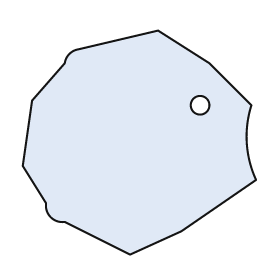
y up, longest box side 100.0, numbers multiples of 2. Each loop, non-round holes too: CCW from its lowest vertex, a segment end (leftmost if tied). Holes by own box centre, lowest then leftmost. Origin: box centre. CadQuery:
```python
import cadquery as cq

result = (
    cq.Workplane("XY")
    .moveTo(-4.0, -48.0)
    .lineTo(18.0, -38.0)
    .lineTo(50.0, -16.0)
    .threePointArc((46.0, 0.0), (48.0, 16.0))
    .lineTo(30.0, 34.0)
    .lineTo(8.0, 48.0)
    .lineTo(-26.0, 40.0)
    .threePointArc((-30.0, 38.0), (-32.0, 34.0))
    .lineTo(-46.0, 18.0)
    .lineTo(-50.0, -10.0)
    .lineTo(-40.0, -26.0)
    .threePointArc((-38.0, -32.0), (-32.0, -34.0))
    .close()
    .moveTo(26.0, 16.0)
    .circle(4.0)
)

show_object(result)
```